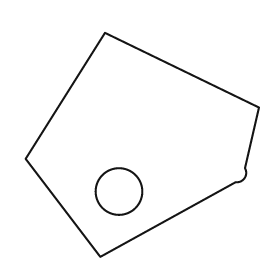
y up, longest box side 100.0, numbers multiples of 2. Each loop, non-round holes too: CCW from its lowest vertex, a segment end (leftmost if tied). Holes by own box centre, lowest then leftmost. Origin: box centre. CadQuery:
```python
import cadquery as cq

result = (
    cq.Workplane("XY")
    .moveTo(-18.0, -48.0)
    .lineTo(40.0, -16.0)
    .threePointArc((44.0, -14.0), (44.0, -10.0))
    .lineTo(50.0, 16.0)
    .lineTo(-16.0, 48.0)
    .lineTo(-50.0, -6.0)
    .close()
    .moveTo(-10.0, -20.0)
    .circle(10.0)
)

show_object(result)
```